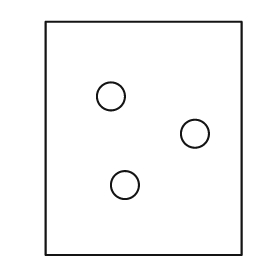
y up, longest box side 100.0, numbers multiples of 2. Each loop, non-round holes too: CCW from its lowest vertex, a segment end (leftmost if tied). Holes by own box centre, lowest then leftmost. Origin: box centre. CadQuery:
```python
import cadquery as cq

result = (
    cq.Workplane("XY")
    .moveTo(-42.0, -50.0)
    .lineTo(42.0, -50.0)
    .lineTo(42.0, 50.0)
    .lineTo(-42.0, 50.0)
    .close()
    .moveTo(-8.0, -20.0)
    .circle(6.0)
    .moveTo(22.0, 2.0)
    .circle(6.0)
    .moveTo(-14.0, 18.0)
    .circle(6.0)
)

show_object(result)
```